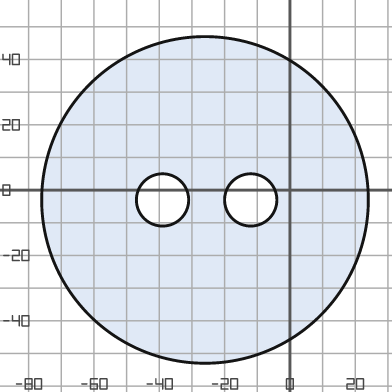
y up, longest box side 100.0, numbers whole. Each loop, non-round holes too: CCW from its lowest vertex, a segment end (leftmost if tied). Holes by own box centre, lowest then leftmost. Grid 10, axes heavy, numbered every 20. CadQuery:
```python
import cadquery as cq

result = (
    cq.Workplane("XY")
    .moveTo(-26.0, -3.0)
    .circle(50.0)
    .moveTo(-39.0, -3.0)
    .circle(8.0)
    .moveTo(-12.0, -3.0)
    .circle(8.0)
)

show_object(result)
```